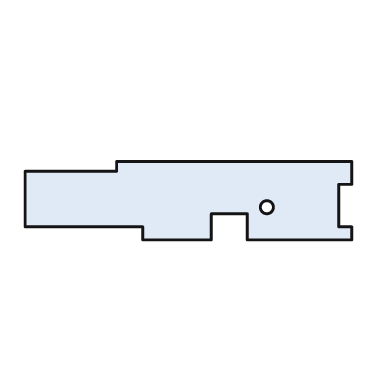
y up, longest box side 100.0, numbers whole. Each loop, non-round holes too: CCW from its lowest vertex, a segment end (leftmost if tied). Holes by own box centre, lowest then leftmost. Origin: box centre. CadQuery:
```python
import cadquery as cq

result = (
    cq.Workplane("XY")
    .moveTo(-14.0, -12.0)
    .lineTo(7.0, -12.0)
    .lineTo(7.0, -4.0)
    .lineTo(18.0, -4.0)
    .lineTo(18.0, -12.0)
    .lineTo(50.0, -12.0)
    .lineTo(50.0, -8.0)
    .lineTo(46.0, -8.0)
    .lineTo(46.0, 5.0)
    .lineTo(50.0, 5.0)
    .lineTo(50.0, 12.0)
    .lineTo(-22.0, 12.0)
    .lineTo(-22.0, 9.0)
    .lineTo(-50.0, 9.0)
    .lineTo(-50.0, -8.0)
    .lineTo(-14.0, -8.0)
    .close()
    .moveTo(24.0, -2.0)
    .circle(2.0)
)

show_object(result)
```